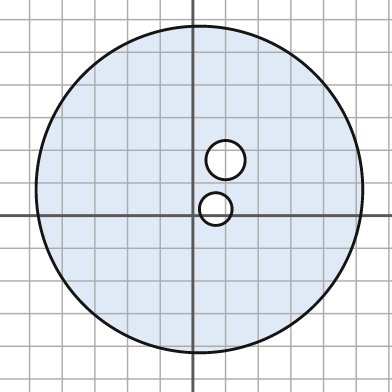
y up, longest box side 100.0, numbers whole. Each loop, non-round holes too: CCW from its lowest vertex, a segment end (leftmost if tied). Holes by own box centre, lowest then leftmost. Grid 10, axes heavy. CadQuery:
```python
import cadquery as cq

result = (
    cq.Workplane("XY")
    .moveTo(2.0, 8.0)
    .circle(50.0)
    .moveTo(7.0, 2.0)
    .circle(5.0)
    .moveTo(10.0, 17.0)
    .circle(6.0)
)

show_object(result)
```